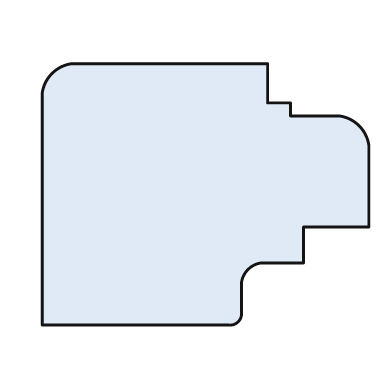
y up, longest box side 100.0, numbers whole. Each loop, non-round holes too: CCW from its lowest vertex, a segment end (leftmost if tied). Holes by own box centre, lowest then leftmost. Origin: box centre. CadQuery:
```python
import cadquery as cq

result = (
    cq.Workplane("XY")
    .moveTo(-50.0, -40.0)
    .lineTo(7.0, -40.0)
    .threePointArc((10.0, -39.0), (11.0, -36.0))
    .lineTo(11.0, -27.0)
    .threePointArc((13.0, -23.0), (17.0, -21.0))
    .lineTo(30.0, -21.0)
    .lineTo(30.0, -10.0)
    .lineTo(50.0, -10.0)
    .lineTo(50.0, 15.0)
    .threePointArc((47.0, 21.0), (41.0, 24.0))
    .lineTo(26.0, 24.0)
    .lineTo(26.0, 28.0)
    .lineTo(19.0, 28.0)
    .lineTo(19.0, 40.0)
    .lineTo(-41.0, 40.0)
    .threePointArc((-47.0, 37.0), (-50.0, 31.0))
    .close()
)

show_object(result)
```